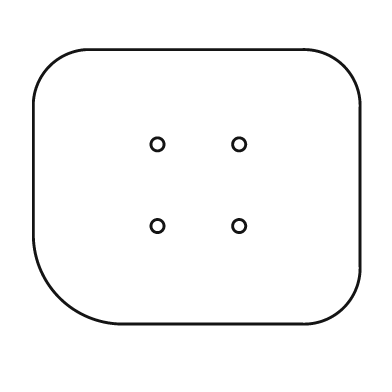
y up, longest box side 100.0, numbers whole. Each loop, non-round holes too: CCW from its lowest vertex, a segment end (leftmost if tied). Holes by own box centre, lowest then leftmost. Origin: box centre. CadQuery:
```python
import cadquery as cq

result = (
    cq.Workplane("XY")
    .moveTo(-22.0, -42.0)
    .lineTo(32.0, -42.0)
    .threePointArc((45.0, -37.0), (50.0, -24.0))
    .lineTo(50.0, 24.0)
    .threePointArc((45.0, 37.0), (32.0, 42.0))
    .lineTo(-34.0, 42.0)
    .threePointArc((-45.0, 37.0), (-50.0, 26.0))
    .lineTo(-50.0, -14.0)
    .threePointArc((-42.0, -34.0), (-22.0, -42.0))
    .close()
    .moveTo(-12.0, -12.0)
    .circle(2.0)
    .moveTo(13.0, -12.0)
    .circle(2.0)
    .moveTo(-12.0, 13.0)
    .circle(2.0)
    .moveTo(13.0, 13.0)
    .circle(2.0)
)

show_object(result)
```